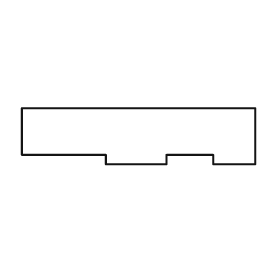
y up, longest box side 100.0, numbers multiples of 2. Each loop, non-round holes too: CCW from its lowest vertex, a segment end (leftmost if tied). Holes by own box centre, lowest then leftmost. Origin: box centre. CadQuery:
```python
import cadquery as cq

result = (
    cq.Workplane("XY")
    .moveTo(-14.0, -12.0)
    .lineTo(12.0, -12.0)
    .lineTo(12.0, -8.0)
    .lineTo(32.0, -8.0)
    .lineTo(32.0, -12.0)
    .lineTo(50.0, -12.0)
    .lineTo(50.0, 12.0)
    .lineTo(-50.0, 12.0)
    .lineTo(-50.0, -8.0)
    .lineTo(-14.0, -8.0)
    .close()
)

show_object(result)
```